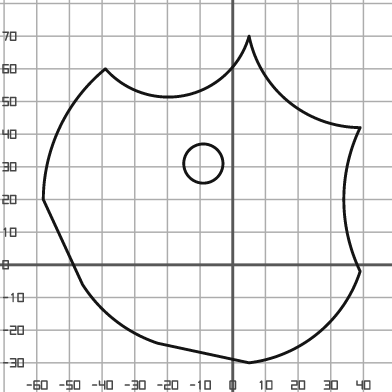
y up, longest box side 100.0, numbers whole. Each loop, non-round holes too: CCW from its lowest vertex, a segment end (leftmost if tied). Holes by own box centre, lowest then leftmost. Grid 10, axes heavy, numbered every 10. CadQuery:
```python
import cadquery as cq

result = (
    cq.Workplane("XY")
    .moveTo(5.0, -30.0)
    .threePointArc((26.0, -21.0), (39.0, -2.0))
    .threePointArc((34.0, 20.0), (39.0, 42.0))
    .threePointArc((17.0, 50.0), (5.0, 70.0))
    .threePointArc((-14.0, 52.0), (-39.0, 60.0))
    .threePointArc((-53.0, 42.0), (-58.0, 20.0))
    .lineTo(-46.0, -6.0)
    .threePointArc((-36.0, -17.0), (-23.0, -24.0))
    .close()
    .moveTo(-9.0, 31.0)
    .circle(6.0)
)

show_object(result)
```